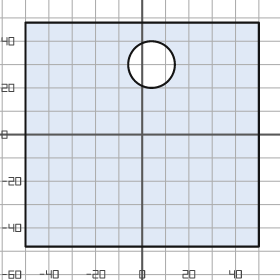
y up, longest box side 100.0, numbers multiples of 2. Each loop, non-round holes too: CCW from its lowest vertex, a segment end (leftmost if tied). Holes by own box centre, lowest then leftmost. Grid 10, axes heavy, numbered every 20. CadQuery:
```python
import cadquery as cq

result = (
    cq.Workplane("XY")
    .moveTo(-50.0, -48.0)
    .lineTo(50.0, -48.0)
    .lineTo(50.0, 48.0)
    .lineTo(-50.0, 48.0)
    .close()
    .moveTo(4.0, 30.0)
    .circle(10.0)
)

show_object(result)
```